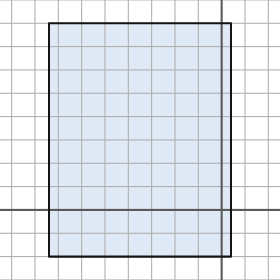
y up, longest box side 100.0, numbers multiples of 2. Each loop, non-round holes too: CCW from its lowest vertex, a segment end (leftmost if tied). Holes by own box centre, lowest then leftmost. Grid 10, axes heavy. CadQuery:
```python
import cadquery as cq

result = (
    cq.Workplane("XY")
    .moveTo(-74.0, -20.0)
    .lineTo(4.0, -20.0)
    .lineTo(4.0, 80.0)
    .lineTo(-74.0, 80.0)
    .close()
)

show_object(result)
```